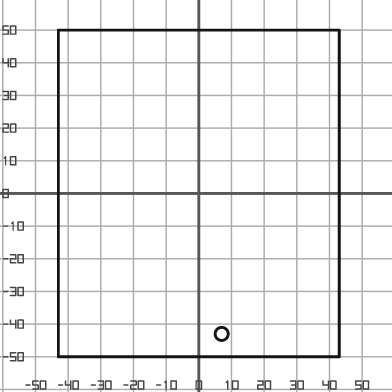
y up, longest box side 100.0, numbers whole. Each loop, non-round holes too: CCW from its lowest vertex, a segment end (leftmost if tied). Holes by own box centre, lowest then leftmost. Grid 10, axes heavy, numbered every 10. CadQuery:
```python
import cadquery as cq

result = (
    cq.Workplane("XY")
    .moveTo(-43.0, -50.0)
    .lineTo(43.0, -50.0)
    .lineTo(43.0, 50.0)
    .lineTo(-43.0, 50.0)
    .close()
    .moveTo(7.0, -43.0)
    .circle(2.0)
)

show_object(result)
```